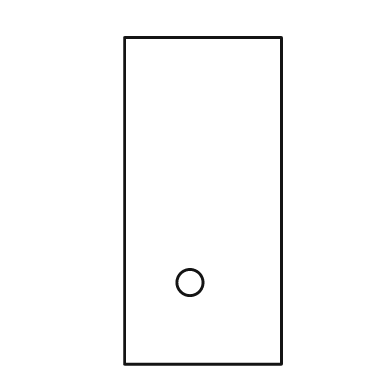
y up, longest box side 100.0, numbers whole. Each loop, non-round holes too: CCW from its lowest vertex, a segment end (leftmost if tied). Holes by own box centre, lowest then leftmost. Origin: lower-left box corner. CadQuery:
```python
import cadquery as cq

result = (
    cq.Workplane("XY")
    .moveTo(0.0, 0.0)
    .lineTo(48.0, 0.0)
    .lineTo(48.0, 100.0)
    .lineTo(0.0, 100.0)
    .close()
    .moveTo(20.0, 25.0)
    .circle(4.0)
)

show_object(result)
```